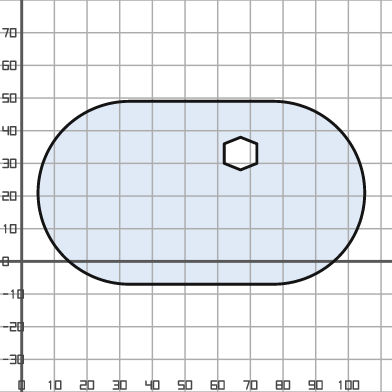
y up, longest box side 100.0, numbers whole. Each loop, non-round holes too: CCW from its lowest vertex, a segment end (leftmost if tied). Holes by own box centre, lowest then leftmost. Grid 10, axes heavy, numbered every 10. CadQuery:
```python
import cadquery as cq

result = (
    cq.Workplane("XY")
    .moveTo(33.0, -7.0)
    .lineTo(77.0, -7.0)
    .threePointArc((105.0, 21.0), (77.0, 49.0))
    .lineTo(33.0, 49.0)
    .threePointArc((5.0, 21.0), (33.0, -7.0))
    .close()
    .moveTo(67.0, 28.0)
    .lineTo(72.0, 30.0)
    .lineTo(72.0, 36.0)
    .lineTo(67.0, 38.0)
    .lineTo(62.0, 36.0)
    .lineTo(62.0, 30.0)
    .close()
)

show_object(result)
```